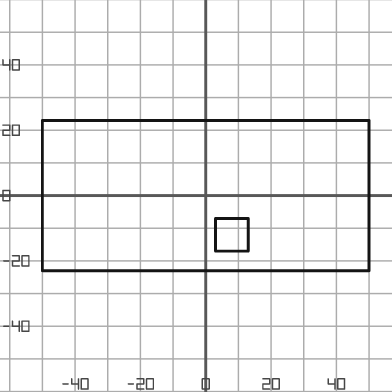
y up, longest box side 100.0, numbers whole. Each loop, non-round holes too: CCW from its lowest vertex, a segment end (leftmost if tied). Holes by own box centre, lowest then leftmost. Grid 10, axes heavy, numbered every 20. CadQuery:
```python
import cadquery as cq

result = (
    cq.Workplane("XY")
    .moveTo(-50.0, -23.0)
    .lineTo(50.0, -23.0)
    .lineTo(50.0, 23.0)
    .lineTo(-50.0, 23.0)
    .close()
    .moveTo(3.0, -17.0)
    .lineTo(13.0, -17.0)
    .lineTo(13.0, -7.0)
    .lineTo(3.0, -7.0)
    .close()
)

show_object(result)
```